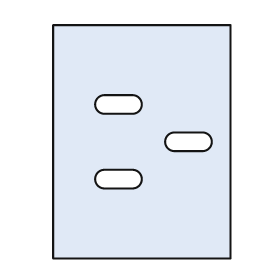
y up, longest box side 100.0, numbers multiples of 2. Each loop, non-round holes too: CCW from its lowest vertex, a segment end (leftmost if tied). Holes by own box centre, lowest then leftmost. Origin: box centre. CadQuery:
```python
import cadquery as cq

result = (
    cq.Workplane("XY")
    .moveTo(-38.0, -50.0)
    .lineTo(38.0, -50.0)
    .lineTo(38.0, 50.0)
    .lineTo(-38.0, 50.0)
    .close()
    .moveTo(-16.0, -20.0)
    .lineTo(-4.0, -20.0)
    .threePointArc((0.0, -16.0), (-4.0, -12.0))
    .lineTo(-16.0, -12.0)
    .threePointArc((-20.0, -16.0), (-16.0, -20.0))
    .close()
    .moveTo(14.0, -4.0)
    .lineTo(26.0, -4.0)
    .threePointArc((30.0, 0.0), (26.0, 4.0))
    .lineTo(14.0, 4.0)
    .threePointArc((10.0, 0.0), (14.0, -4.0))
    .close()
    .moveTo(-16.0, 12.0)
    .lineTo(-4.0, 12.0)
    .threePointArc((0.0, 16.0), (-4.0, 20.0))
    .lineTo(-16.0, 20.0)
    .threePointArc((-20.0, 16.0), (-16.0, 12.0))
    .close()
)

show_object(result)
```